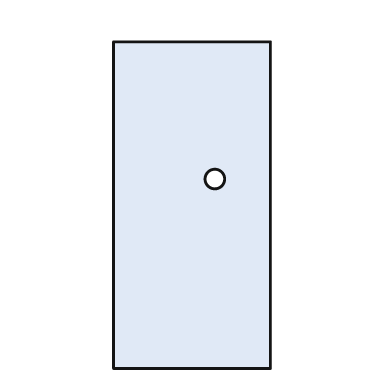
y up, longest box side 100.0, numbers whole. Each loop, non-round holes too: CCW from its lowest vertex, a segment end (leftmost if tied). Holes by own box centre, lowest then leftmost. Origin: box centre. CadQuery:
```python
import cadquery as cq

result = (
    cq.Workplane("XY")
    .moveTo(-24.0, -50.0)
    .lineTo(24.0, -50.0)
    .lineTo(24.0, 50.0)
    .lineTo(-24.0, 50.0)
    .close()
    .moveTo(7.0, 8.0)
    .circle(3.0)
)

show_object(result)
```